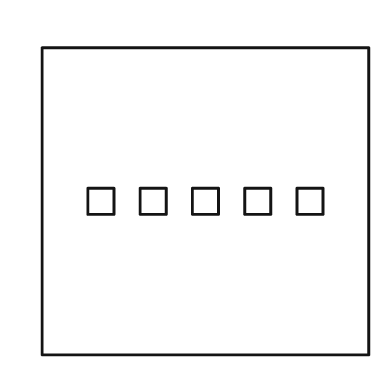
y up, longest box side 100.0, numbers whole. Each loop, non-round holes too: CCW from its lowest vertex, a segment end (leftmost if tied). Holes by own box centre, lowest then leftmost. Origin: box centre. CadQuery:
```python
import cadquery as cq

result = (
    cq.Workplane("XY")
    .moveTo(-50.0, -47.0)
    .lineTo(50.0, -47.0)
    .lineTo(50.0, 47.0)
    .lineTo(-50.0, 47.0)
    .close()
    .moveTo(-36.0, -4.0)
    .lineTo(-28.0, -4.0)
    .lineTo(-28.0, 4.0)
    .lineTo(-36.0, 4.0)
    .close()
    .moveTo(-20.0, -4.0)
    .lineTo(-12.0, -4.0)
    .lineTo(-12.0, 4.0)
    .lineTo(-20.0, 4.0)
    .close()
    .moveTo(-4.0, -4.0)
    .lineTo(4.0, -4.0)
    .lineTo(4.0, 4.0)
    .lineTo(-4.0, 4.0)
    .close()
    .moveTo(12.0, -4.0)
    .lineTo(20.0, -4.0)
    .lineTo(20.0, 4.0)
    .lineTo(12.0, 4.0)
    .close()
    .moveTo(28.0, -4.0)
    .lineTo(36.0, -4.0)
    .lineTo(36.0, 4.0)
    .lineTo(28.0, 4.0)
    .close()
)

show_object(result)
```